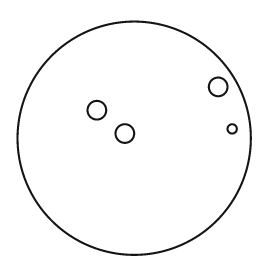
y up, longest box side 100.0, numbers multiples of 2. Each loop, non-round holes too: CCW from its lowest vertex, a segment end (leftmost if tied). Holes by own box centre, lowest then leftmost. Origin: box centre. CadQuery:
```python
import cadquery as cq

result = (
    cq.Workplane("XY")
    .moveTo(0.0, 0.0)
    .circle(50.0)
    .moveTo(-4.0, 2.0)
    .circle(4.0)
    .moveTo(42.0, 4.0)
    .circle(2.0)
    .moveTo(-16.0, 12.0)
    .circle(4.0)
    .moveTo(36.0, 22.0)
    .circle(4.0)
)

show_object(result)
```